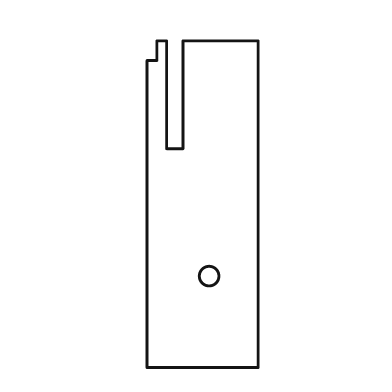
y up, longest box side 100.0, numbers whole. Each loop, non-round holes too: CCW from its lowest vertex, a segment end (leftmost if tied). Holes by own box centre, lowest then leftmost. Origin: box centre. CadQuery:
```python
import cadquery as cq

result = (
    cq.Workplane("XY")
    .moveTo(-17.0, -50.0)
    .lineTo(17.0, -50.0)
    .lineTo(17.0, 50.0)
    .lineTo(-6.0, 50.0)
    .lineTo(-6.0, 17.0)
    .lineTo(-11.0, 17.0)
    .lineTo(-11.0, 50.0)
    .lineTo(-14.0, 50.0)
    .lineTo(-14.0, 44.0)
    .lineTo(-17.0, 44.0)
    .close()
    .moveTo(2.0, -22.0)
    .circle(3.0)
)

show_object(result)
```